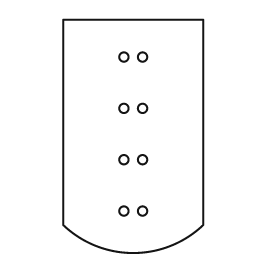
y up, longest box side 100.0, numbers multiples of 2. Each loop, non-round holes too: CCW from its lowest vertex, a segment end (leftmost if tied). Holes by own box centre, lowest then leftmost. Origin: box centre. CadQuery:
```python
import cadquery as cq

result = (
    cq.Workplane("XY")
    .moveTo(-30.0, -38.0)
    .threePointArc((0.0, -50.0), (30.0, -38.0))
    .lineTo(30.0, 50.0)
    .lineTo(-30.0, 50.0)
    .close()
    .moveTo(-4.0, -32.0)
    .circle(2.0)
    .moveTo(4.0, -32.0)
    .circle(2.0)
    .moveTo(-4.0, -10.0)
    .circle(2.0)
    .moveTo(4.0, -10.0)
    .circle(2.0)
    .moveTo(-4.0, 12.0)
    .circle(2.0)
    .moveTo(4.0, 12.0)
    .circle(2.0)
    .moveTo(-4.0, 34.0)
    .circle(2.0)
    .moveTo(4.0, 34.0)
    .circle(2.0)
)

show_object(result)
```